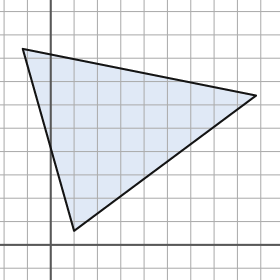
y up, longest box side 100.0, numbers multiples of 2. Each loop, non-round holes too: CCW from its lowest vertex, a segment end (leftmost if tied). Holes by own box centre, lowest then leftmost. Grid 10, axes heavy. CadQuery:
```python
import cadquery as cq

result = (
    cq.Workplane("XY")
    .moveTo(10.0, 6.0)
    .lineTo(88.0, 64.0)
    .lineTo(-12.0, 84.0)
    .close()
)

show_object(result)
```